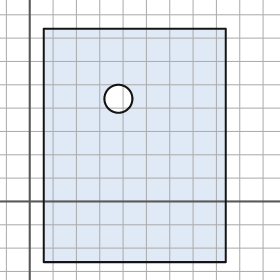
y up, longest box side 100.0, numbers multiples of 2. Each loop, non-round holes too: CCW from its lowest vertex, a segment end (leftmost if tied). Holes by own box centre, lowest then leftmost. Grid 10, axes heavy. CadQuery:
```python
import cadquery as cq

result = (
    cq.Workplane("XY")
    .moveTo(6.0, -26.0)
    .lineTo(84.0, -26.0)
    .lineTo(84.0, 74.0)
    .lineTo(6.0, 74.0)
    .close()
    .moveTo(38.0, 44.0)
    .circle(6.0)
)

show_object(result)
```